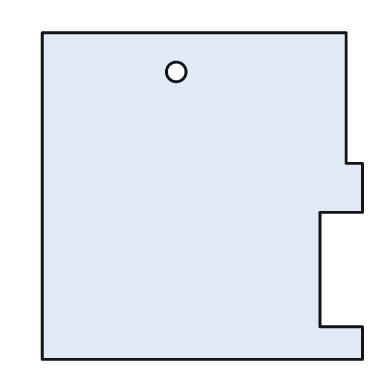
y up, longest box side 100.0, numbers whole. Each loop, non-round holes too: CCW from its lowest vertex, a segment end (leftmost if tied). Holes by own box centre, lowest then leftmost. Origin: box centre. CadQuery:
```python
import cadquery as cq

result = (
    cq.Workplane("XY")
    .moveTo(-49.0, -50.0)
    .lineTo(49.0, -50.0)
    .lineTo(49.0, -40.0)
    .lineTo(36.0, -40.0)
    .lineTo(36.0, -5.0)
    .lineTo(49.0, -5.0)
    .lineTo(49.0, 10.0)
    .lineTo(44.0, 10.0)
    .lineTo(44.0, 50.0)
    .lineTo(-49.0, 50.0)
    .close()
    .moveTo(-8.0, 38.0)
    .circle(3.0)
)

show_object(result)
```